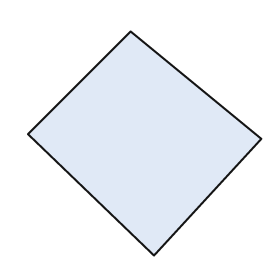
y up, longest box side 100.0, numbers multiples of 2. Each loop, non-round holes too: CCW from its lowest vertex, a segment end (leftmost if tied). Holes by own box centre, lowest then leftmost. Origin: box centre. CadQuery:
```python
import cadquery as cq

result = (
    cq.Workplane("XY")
    .moveTo(4.0, -48.0)
    .lineTo(50.0, 2.0)
    .lineTo(-6.0, 48.0)
    .lineTo(-50.0, 4.0)
    .close()
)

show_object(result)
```